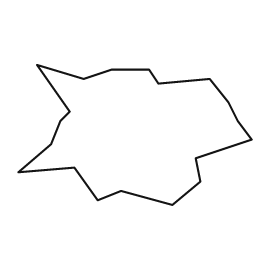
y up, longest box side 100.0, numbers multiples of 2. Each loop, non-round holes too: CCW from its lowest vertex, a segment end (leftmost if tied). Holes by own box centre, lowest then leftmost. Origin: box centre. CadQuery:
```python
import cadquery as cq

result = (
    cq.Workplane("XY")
    .moveTo(16.0, -30.0)
    .lineTo(28.0, -20.0)
    .lineTo(26.0, -10.0)
    .lineTo(50.0, -2.0)
    .lineTo(44.0, 6.0)
    .lineTo(40.0, 14.0)
    .lineTo(32.0, 24.0)
    .lineTo(10.0, 22.0)
    .lineTo(6.0, 28.0)
    .lineTo(-10.0, 28.0)
    .lineTo(-22.0, 24.0)
    .lineTo(-42.0, 30.0)
    .lineTo(-28.0, 10.0)
    .lineTo(-32.0, 6.0)
    .lineTo(-36.0, -4.0)
    .lineTo(-50.0, -16.0)
    .lineTo(-26.0, -14.0)
    .lineTo(-16.0, -28.0)
    .lineTo(-6.0, -24.0)
    .close()
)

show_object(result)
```